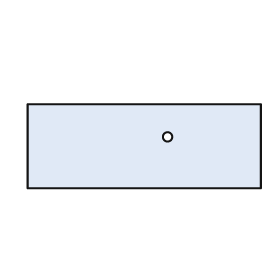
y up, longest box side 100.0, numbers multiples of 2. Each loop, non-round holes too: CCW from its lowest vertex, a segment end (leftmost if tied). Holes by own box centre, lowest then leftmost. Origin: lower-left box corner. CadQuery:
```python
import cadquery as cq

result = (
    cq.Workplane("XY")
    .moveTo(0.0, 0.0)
    .lineTo(100.0, 0.0)
    .lineTo(100.0, 36.0)
    .lineTo(0.0, 36.0)
    .close()
    .moveTo(60.0, 22.0)
    .circle(2.0)
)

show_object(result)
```